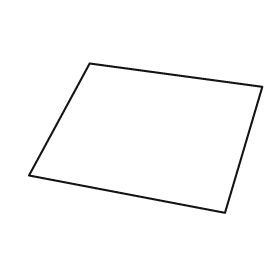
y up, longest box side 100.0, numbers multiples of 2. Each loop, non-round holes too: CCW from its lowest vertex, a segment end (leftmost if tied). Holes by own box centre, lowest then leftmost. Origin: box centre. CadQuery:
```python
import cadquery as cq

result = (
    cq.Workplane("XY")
    .moveTo(34.0, -32.0)
    .lineTo(50.0, 22.0)
    .lineTo(-24.0, 32.0)
    .lineTo(-50.0, -16.0)
    .close()
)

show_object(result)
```